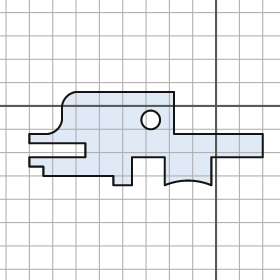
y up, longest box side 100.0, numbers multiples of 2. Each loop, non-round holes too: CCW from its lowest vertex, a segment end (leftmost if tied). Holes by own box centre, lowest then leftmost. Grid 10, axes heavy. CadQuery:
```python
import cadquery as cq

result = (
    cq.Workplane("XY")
    .moveTo(-44.0, -34.0)
    .lineTo(-36.0, -34.0)
    .lineTo(-36.0, -22.0)
    .lineTo(-22.0, -22.0)
    .lineTo(-22.0, -34.0)
    .threePointArc((-12.0, -32.0), (-2.0, -34.0))
    .lineTo(-2.0, -22.0)
    .lineTo(20.0, -22.0)
    .lineTo(20.0, -12.0)
    .lineTo(-18.0, -12.0)
    .lineTo(-18.0, 6.0)
    .lineTo(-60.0, 6.0)
    .threePointArc((-64.0, 4.0), (-66.0, 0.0))
    .lineTo(-66.0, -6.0)
    .threePointArc((-68.0, -10.0), (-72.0, -12.0))
    .lineTo(-80.0, -12.0)
    .lineTo(-80.0, -16.0)
    .lineTo(-56.0, -16.0)
    .lineTo(-56.0, -22.0)
    .lineTo(-80.0, -22.0)
    .lineTo(-80.0, -26.0)
    .lineTo(-74.0, -26.0)
    .lineTo(-74.0, -30.0)
    .lineTo(-44.0, -30.0)
    .close()
    .moveTo(-28.0, -6.0)
    .circle(4.0)
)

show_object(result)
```